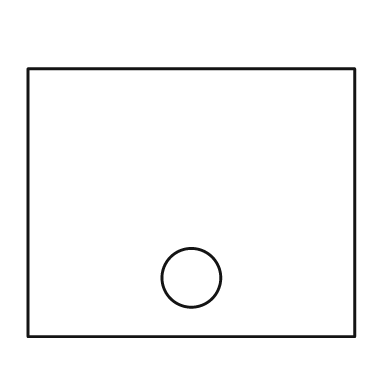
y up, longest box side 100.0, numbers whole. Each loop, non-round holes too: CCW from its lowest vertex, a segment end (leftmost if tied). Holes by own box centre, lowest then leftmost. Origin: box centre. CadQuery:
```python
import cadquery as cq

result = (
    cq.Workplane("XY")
    .moveTo(-50.0, -41.0)
    .lineTo(50.0, -41.0)
    .lineTo(50.0, 41.0)
    .lineTo(-50.0, 41.0)
    .close()
    .moveTo(0.0, -23.0)
    .circle(9.0)
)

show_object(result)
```